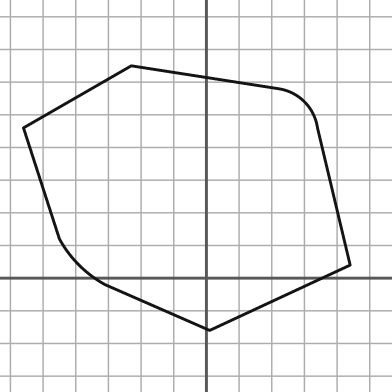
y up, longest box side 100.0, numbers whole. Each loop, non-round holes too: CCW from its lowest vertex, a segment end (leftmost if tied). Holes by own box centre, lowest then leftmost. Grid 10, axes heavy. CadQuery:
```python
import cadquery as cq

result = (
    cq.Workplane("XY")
    .moveTo(1.0, -16.0)
    .lineTo(44.0, 4.0)
    .lineTo(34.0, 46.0)
    .threePointArc((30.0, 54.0), (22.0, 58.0))
    .lineTo(-23.0, 65.0)
    .lineTo(-56.0, 46.0)
    .lineTo(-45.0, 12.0)
    .threePointArc((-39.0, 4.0), (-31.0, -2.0))
    .close()
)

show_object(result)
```